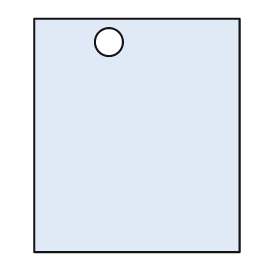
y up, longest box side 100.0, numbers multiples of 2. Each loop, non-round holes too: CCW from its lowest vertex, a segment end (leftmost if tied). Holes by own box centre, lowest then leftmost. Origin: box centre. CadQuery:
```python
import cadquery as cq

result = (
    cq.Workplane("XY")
    .moveTo(-44.0, -50.0)
    .lineTo(44.0, -50.0)
    .lineTo(44.0, 50.0)
    .lineTo(-44.0, 50.0)
    .close()
    .moveTo(-12.0, 40.0)
    .circle(6.0)
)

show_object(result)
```